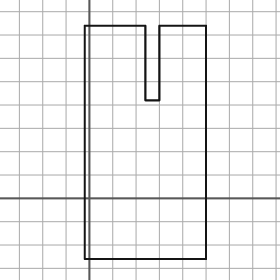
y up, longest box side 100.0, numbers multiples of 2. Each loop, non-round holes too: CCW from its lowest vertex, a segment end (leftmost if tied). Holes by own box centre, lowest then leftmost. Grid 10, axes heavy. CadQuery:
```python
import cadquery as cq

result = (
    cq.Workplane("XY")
    .moveTo(-2.0, -26.0)
    .lineTo(50.0, -26.0)
    .lineTo(50.0, 74.0)
    .lineTo(30.0, 74.0)
    .lineTo(30.0, 42.0)
    .lineTo(24.0, 42.0)
    .lineTo(24.0, 74.0)
    .lineTo(-2.0, 74.0)
    .close()
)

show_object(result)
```